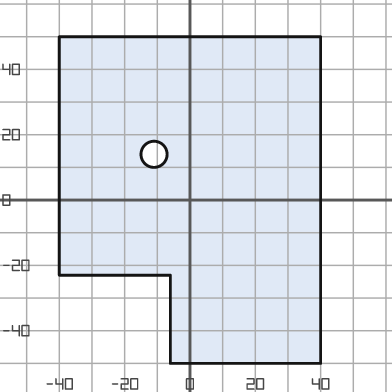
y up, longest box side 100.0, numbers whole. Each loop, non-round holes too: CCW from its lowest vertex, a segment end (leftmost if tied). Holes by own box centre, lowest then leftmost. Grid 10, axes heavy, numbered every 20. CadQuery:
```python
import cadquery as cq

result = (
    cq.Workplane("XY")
    .moveTo(-6.0, -50.0)
    .lineTo(40.0, -50.0)
    .lineTo(40.0, 50.0)
    .lineTo(-40.0, 50.0)
    .lineTo(-40.0, -23.0)
    .lineTo(-6.0, -23.0)
    .close()
    .moveTo(-11.0, 14.0)
    .circle(4.0)
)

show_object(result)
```